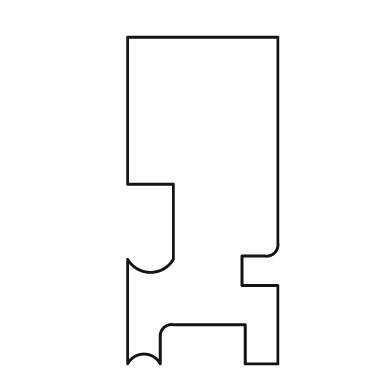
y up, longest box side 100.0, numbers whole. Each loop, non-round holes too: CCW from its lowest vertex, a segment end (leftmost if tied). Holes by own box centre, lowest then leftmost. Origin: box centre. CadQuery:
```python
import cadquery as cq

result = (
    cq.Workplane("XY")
    .moveTo(-23.0, -50.0)
    .threePointArc((-18.0, -47.0), (-13.0, -50.0))
    .lineTo(-13.0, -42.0)
    .threePointArc((-12.0, -39.0), (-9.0, -38.0))
    .lineTo(13.0, -38.0)
    .lineTo(13.0, -50.0)
    .lineTo(23.0, -50.0)
    .lineTo(23.0, -26.0)
    .lineTo(12.0, -26.0)
    .lineTo(12.0, -17.0)
    .lineTo(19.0, -17.0)
    .threePointArc((22.0, -16.0), (23.0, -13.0))
    .lineTo(23.0, 50.0)
    .lineTo(-23.0, 50.0)
    .lineTo(-23.0, 5.0)
    .lineTo(-9.0, 5.0)
    .lineTo(-9.0, -18.0)
    .threePointArc((-16.0, -22.0), (-23.0, -18.0))
    .close()
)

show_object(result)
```